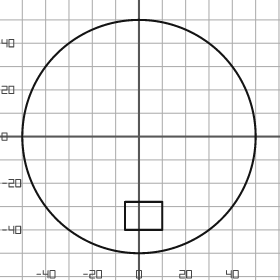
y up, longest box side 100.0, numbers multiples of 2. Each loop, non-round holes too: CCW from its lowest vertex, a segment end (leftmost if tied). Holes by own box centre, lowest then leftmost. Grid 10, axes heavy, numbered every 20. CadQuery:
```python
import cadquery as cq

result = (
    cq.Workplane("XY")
    .moveTo(0.0, 0.0)
    .circle(50.0)
    .moveTo(-6.0, -40.0)
    .lineTo(10.0, -40.0)
    .lineTo(10.0, -28.0)
    .lineTo(-6.0, -28.0)
    .close()
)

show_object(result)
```